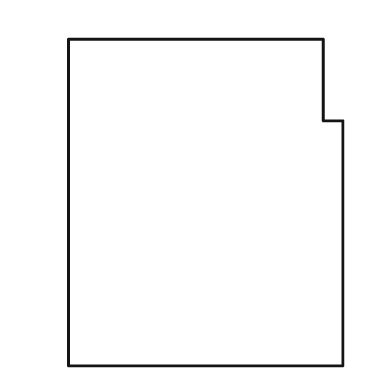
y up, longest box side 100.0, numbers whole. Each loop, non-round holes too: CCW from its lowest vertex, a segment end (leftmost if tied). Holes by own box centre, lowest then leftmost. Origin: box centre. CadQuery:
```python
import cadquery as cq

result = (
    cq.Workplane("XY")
    .moveTo(-42.0, -50.0)
    .lineTo(42.0, -50.0)
    .lineTo(42.0, 25.0)
    .lineTo(36.0, 25.0)
    .lineTo(36.0, 50.0)
    .lineTo(-42.0, 50.0)
    .close()
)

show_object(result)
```